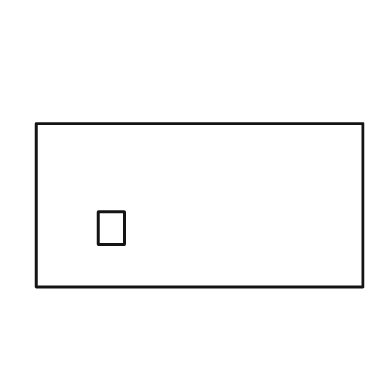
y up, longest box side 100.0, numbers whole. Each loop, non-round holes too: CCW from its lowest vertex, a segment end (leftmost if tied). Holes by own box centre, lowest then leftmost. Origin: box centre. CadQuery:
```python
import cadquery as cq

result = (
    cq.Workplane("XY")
    .moveTo(-50.0, -25.0)
    .lineTo(50.0, -25.0)
    .lineTo(50.0, 25.0)
    .lineTo(-50.0, 25.0)
    .close()
    .moveTo(-31.0, -12.0)
    .lineTo(-23.0, -12.0)
    .lineTo(-23.0, -2.0)
    .lineTo(-31.0, -2.0)
    .close()
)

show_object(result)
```